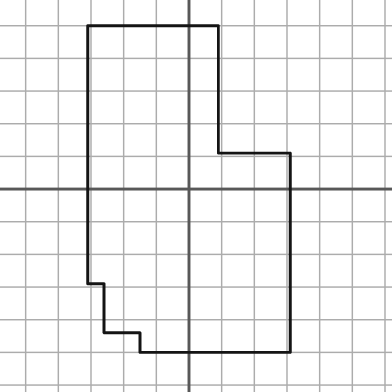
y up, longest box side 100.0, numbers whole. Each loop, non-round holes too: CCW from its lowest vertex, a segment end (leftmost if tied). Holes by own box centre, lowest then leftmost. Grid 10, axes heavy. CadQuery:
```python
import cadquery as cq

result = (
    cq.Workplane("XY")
    .moveTo(-15.0, -50.0)
    .lineTo(31.0, -50.0)
    .lineTo(31.0, 11.0)
    .lineTo(9.0, 11.0)
    .lineTo(9.0, 50.0)
    .lineTo(-31.0, 50.0)
    .lineTo(-31.0, -29.0)
    .lineTo(-26.0, -29.0)
    .lineTo(-26.0, -44.0)
    .lineTo(-15.0, -44.0)
    .close()
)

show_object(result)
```